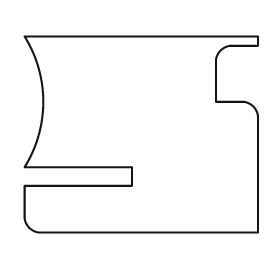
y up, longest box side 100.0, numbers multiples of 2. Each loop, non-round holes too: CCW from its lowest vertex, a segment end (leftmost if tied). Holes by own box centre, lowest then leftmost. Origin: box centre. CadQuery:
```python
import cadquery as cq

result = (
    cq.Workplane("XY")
    .moveTo(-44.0, -42.0)
    .lineTo(50.0, -42.0)
    .lineTo(50.0, 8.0)
    .threePointArc((48.0, 12.0), (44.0, 14.0))
    .lineTo(32.0, 14.0)
    .lineTo(32.0, 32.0)
    .threePointArc((34.0, 36.0), (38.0, 38.0))
    .lineTo(50.0, 38.0)
    .lineTo(50.0, 42.0)
    .lineTo(-50.0, 42.0)
    .threePointArc((-42.0, 14.0), (-50.0, -14.0))
    .lineTo(-4.0, -14.0)
    .lineTo(-4.0, -22.0)
    .lineTo(-50.0, -22.0)
    .lineTo(-50.0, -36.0)
    .threePointArc((-48.0, -40.0), (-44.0, -42.0))
    .close()
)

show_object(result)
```